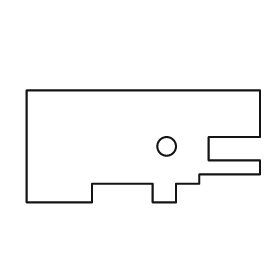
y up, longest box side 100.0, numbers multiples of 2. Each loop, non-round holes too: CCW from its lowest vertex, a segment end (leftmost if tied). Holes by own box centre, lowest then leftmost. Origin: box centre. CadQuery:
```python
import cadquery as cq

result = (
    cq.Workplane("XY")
    .moveTo(-50.0, -24.0)
    .lineTo(-22.0, -24.0)
    .lineTo(-22.0, -16.0)
    .lineTo(4.0, -16.0)
    .lineTo(4.0, -24.0)
    .lineTo(14.0, -24.0)
    .lineTo(14.0, -16.0)
    .lineTo(24.0, -16.0)
    .lineTo(24.0, -12.0)
    .lineTo(50.0, -12.0)
    .lineTo(50.0, -6.0)
    .lineTo(28.0, -6.0)
    .lineTo(28.0, 4.0)
    .lineTo(50.0, 4.0)
    .lineTo(50.0, 24.0)
    .lineTo(-50.0, 24.0)
    .close()
    .moveTo(10.0, 0.0)
    .circle(4.0)
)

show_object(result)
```